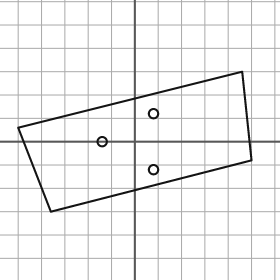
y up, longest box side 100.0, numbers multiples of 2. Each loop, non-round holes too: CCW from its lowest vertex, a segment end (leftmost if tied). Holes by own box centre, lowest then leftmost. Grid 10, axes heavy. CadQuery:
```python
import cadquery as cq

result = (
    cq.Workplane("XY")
    .moveTo(-36.0, -30.0)
    .lineTo(50.0, -8.0)
    .lineTo(46.0, 30.0)
    .lineTo(-50.0, 6.0)
    .close()
    .moveTo(8.0, -12.0)
    .circle(2.0)
    .moveTo(-14.0, 0.0)
    .circle(2.0)
    .moveTo(8.0, 12.0)
    .circle(2.0)
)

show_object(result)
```